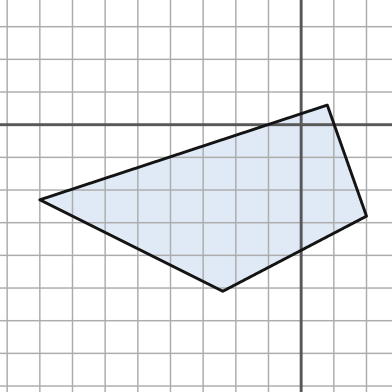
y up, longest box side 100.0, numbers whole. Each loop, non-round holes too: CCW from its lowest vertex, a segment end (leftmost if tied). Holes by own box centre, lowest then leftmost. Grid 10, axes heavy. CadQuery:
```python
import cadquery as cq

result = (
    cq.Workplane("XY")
    .moveTo(-24.0, -51.0)
    .lineTo(20.0, -28.0)
    .lineTo(8.0, 6.0)
    .lineTo(-80.0, -23.0)
    .close()
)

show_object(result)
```